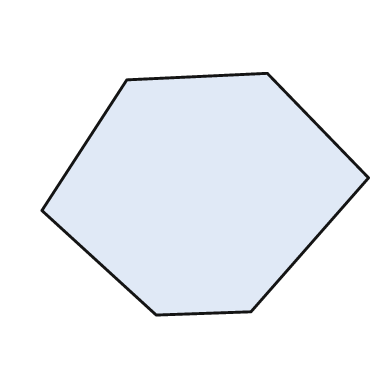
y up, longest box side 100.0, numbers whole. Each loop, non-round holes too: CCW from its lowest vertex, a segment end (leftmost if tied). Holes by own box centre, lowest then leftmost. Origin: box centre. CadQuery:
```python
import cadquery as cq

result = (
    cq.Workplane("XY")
    .moveTo(-15.0, -37.0)
    .lineTo(14.0, -36.0)
    .lineTo(50.0, 5.0)
    .lineTo(19.0, 37.0)
    .lineTo(-24.0, 35.0)
    .lineTo(-50.0, -5.0)
    .close()
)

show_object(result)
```